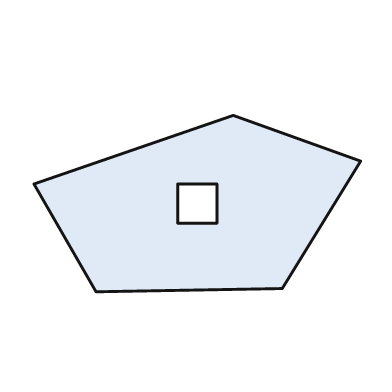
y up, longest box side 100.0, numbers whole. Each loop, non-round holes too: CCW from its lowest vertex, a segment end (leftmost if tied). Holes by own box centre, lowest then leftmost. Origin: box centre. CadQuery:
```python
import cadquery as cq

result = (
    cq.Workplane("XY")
    .moveTo(-31.0, -27.0)
    .lineTo(26.0, -26.0)
    .lineTo(50.0, 13.0)
    .lineTo(11.0, 27.0)
    .lineTo(-50.0, 6.0)
    .close()
    .moveTo(-6.0, -6.0)
    .lineTo(6.0, -6.0)
    .lineTo(6.0, 6.0)
    .lineTo(-6.0, 6.0)
    .close()
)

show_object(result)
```